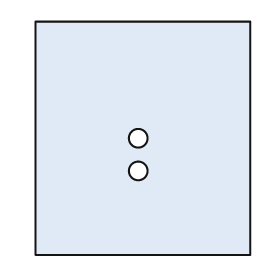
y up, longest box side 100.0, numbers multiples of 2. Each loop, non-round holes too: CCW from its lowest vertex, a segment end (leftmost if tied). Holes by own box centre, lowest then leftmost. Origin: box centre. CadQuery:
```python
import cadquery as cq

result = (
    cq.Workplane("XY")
    .moveTo(-46.0, -50.0)
    .lineTo(46.0, -50.0)
    .lineTo(46.0, 50.0)
    .lineTo(-46.0, 50.0)
    .close()
    .moveTo(-2.0, -14.0)
    .circle(4.0)
    .moveTo(-2.0, 0.0)
    .circle(4.0)
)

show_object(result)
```